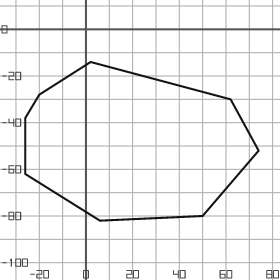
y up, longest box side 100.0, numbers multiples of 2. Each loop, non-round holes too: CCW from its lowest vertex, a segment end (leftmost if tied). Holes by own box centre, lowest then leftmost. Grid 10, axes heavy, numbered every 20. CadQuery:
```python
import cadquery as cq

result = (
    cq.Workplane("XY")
    .moveTo(6.0, -82.0)
    .lineTo(50.0, -80.0)
    .lineTo(74.0, -52.0)
    .lineTo(62.0, -30.0)
    .lineTo(2.0, -14.0)
    .lineTo(-20.0, -28.0)
    .lineTo(-26.0, -38.0)
    .lineTo(-26.0, -62.0)
    .close()
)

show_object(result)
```